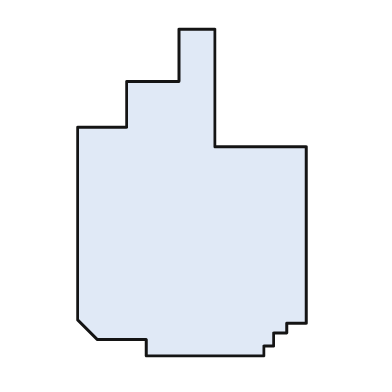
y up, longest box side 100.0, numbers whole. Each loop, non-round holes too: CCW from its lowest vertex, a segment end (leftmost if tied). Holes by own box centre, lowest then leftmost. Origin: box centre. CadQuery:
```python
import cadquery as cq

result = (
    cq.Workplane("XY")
    .moveTo(-14.0, -50.0)
    .lineTo(22.0, -50.0)
    .lineTo(22.0, -47.0)
    .lineTo(25.0, -47.0)
    .lineTo(25.0, -43.0)
    .lineTo(29.0, -43.0)
    .lineTo(29.0, -40.0)
    .lineTo(35.0, -40.0)
    .lineTo(35.0, 14.0)
    .lineTo(7.0, 14.0)
    .lineTo(7.0, 50.0)
    .lineTo(-4.0, 50.0)
    .lineTo(-4.0, 34.0)
    .lineTo(-20.0, 34.0)
    .lineTo(-20.0, 20.0)
    .lineTo(-35.0, 20.0)
    .lineTo(-35.0, -39.0)
    .lineTo(-29.0, -45.0)
    .lineTo(-14.0, -45.0)
    .close()
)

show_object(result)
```